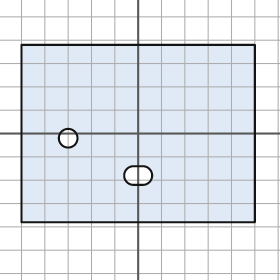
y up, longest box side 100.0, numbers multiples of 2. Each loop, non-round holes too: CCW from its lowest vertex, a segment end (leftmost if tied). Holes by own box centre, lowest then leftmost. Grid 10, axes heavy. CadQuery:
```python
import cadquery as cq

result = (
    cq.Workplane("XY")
    .moveTo(-50.0, -38.0)
    .lineTo(50.0, -38.0)
    .lineTo(50.0, 38.0)
    .lineTo(-50.0, 38.0)
    .close()
    .moveTo(-2.0, -22.0)
    .lineTo(2.0, -22.0)
    .threePointArc((6.0, -18.0), (2.0, -14.0))
    .lineTo(-2.0, -14.0)
    .threePointArc((-6.0, -18.0), (-2.0, -22.0))
    .close()
    .moveTo(-30.0, -2.0)
    .circle(4.0)
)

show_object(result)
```